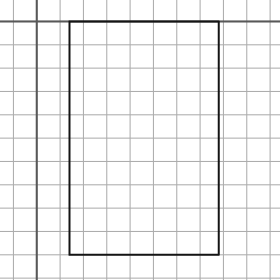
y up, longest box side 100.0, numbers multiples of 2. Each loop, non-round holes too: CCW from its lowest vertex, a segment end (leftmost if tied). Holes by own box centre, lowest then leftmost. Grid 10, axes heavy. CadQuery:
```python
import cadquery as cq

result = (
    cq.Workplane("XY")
    .moveTo(14.0, -100.0)
    .lineTo(78.0, -100.0)
    .lineTo(78.0, 0.0)
    .lineTo(14.0, 0.0)
    .close()
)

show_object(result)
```